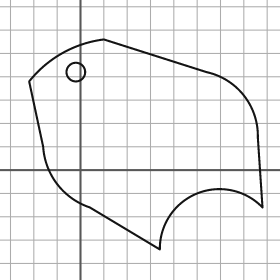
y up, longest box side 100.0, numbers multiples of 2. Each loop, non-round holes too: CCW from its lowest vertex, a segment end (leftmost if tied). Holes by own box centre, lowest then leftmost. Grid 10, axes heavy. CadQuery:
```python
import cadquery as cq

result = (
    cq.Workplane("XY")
    .moveTo(34.0, -34.0)
    .threePointArc((50.0, -10.0), (78.0, -16.0))
    .lineTo(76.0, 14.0)
    .threePointArc((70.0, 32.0), (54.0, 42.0))
    .lineTo(10.0, 56.0)
    .threePointArc((-8.0, 50.0), (-22.0, 38.0))
    .lineTo(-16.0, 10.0)
    .threePointArc((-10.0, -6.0), (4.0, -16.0))
    .close()
    .moveTo(-2.0, 42.0)
    .circle(4.0)
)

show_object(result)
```